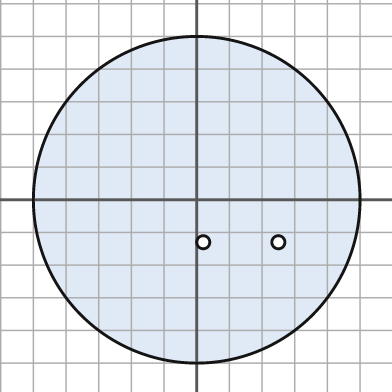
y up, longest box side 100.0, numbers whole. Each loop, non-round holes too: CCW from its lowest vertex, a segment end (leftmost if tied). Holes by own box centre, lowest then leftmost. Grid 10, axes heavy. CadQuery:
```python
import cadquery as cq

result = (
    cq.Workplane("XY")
    .moveTo(0.0, 0.0)
    .circle(50.0)
    .moveTo(2.0, -13.0)
    .circle(2.0)
    .moveTo(25.0, -13.0)
    .circle(2.0)
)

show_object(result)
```